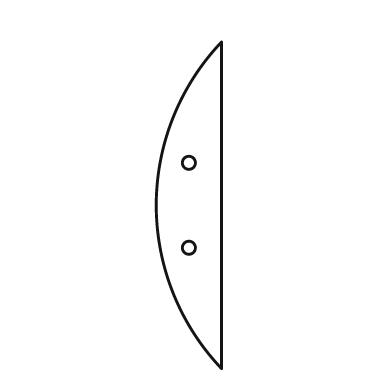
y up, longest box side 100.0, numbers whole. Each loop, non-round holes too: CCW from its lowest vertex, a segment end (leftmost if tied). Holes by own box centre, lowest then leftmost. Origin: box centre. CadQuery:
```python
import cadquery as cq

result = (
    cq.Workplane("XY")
    .moveTo(10.0, -50.0)
    .lineTo(10.0, 50.0)
    .threePointArc((-10.0, 0.0), (10.0, -50.0))
    .close()
    .moveTo(0.0, -13.0)
    .circle(2.0)
    .moveTo(0.0, 13.0)
    .circle(2.0)
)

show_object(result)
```